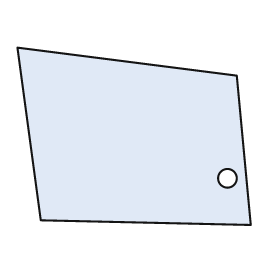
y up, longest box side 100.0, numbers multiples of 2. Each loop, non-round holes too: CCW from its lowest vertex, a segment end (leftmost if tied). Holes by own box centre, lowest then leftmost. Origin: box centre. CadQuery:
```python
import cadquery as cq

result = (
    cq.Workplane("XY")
    .moveTo(50.0, -38.0)
    .lineTo(44.0, 26.0)
    .lineTo(-50.0, 38.0)
    .lineTo(-40.0, -36.0)
    .close()
    .moveTo(40.0, -18.0)
    .circle(4.0)
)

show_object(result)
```